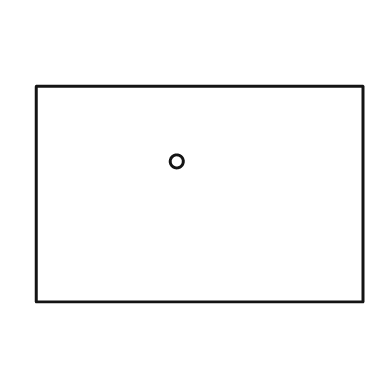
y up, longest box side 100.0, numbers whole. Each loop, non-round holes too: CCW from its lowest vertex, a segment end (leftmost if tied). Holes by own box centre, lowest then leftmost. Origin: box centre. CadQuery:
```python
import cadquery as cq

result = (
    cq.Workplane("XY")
    .moveTo(-50.0, -33.0)
    .lineTo(50.0, -33.0)
    .lineTo(50.0, 33.0)
    .lineTo(-50.0, 33.0)
    .close()
    .moveTo(-7.0, 10.0)
    .circle(2.0)
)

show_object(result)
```